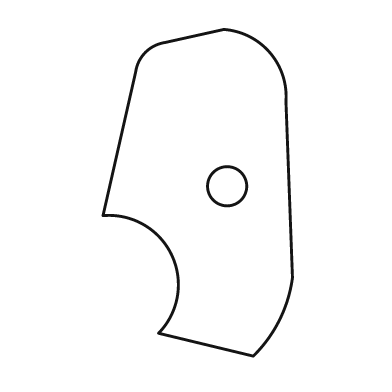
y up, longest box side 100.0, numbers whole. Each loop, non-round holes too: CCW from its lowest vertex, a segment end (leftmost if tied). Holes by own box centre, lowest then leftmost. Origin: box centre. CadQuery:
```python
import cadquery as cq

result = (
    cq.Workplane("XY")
    .moveTo(17.0, -50.0)
    .threePointArc((25.0, -39.0), (29.0, -26.0))
    .lineTo(27.0, 28.0)
    .threePointArc((22.0, 43.0), (8.0, 50.0))
    .lineTo(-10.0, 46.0)
    .threePointArc((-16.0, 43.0), (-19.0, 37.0))
    .lineTo(-29.0, -7.0)
    .threePointArc((-8.0, -19.0), (-12.0, -43.0))
    .close()
    .moveTo(9.0, 2.0)
    .circle(6.0)
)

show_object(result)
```